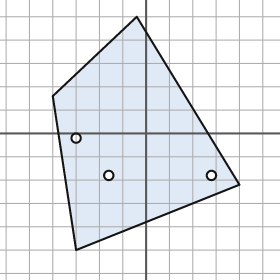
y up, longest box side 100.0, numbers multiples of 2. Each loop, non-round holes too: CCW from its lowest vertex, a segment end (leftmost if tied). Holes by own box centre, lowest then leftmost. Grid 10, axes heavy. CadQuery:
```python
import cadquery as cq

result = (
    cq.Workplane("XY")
    .moveTo(-30.0, -50.0)
    .lineTo(40.0, -22.0)
    .lineTo(-4.0, 50.0)
    .lineTo(-40.0, 16.0)
    .close()
    .moveTo(-16.0, -18.0)
    .circle(2.0)
    .moveTo(28.0, -18.0)
    .circle(2.0)
    .moveTo(-30.0, -2.0)
    .circle(2.0)
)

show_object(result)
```